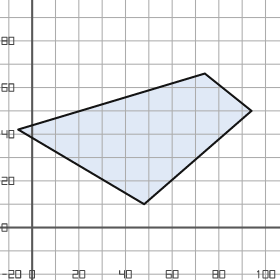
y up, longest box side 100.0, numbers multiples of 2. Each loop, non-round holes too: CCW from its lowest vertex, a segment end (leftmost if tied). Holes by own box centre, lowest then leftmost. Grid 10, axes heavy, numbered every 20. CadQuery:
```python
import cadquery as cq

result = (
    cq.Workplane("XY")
    .moveTo(48.0, 10.0)
    .lineTo(94.0, 50.0)
    .lineTo(74.0, 66.0)
    .lineTo(-6.0, 42.0)
    .close()
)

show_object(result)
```